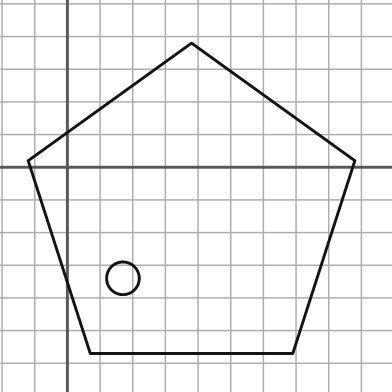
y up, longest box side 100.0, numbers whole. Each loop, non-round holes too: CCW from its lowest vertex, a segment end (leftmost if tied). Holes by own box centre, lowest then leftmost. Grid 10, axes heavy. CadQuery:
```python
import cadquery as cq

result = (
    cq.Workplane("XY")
    .moveTo(7.0, -57.0)
    .lineTo(69.0, -57.0)
    .lineTo(88.0, 2.0)
    .lineTo(38.0, 38.0)
    .lineTo(-12.0, 2.0)
    .close()
    .moveTo(17.0, -34.0)
    .circle(5.0)
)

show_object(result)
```